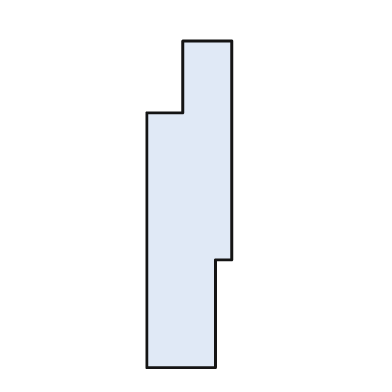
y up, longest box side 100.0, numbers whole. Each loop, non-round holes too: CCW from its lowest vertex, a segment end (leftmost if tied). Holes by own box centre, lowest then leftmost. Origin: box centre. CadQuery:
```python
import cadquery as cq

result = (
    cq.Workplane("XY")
    .moveTo(-13.0, -50.0)
    .lineTo(8.0, -50.0)
    .lineTo(8.0, -17.0)
    .lineTo(13.0, -17.0)
    .lineTo(13.0, 50.0)
    .lineTo(-2.0, 50.0)
    .lineTo(-2.0, 28.0)
    .lineTo(-13.0, 28.0)
    .close()
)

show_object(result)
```